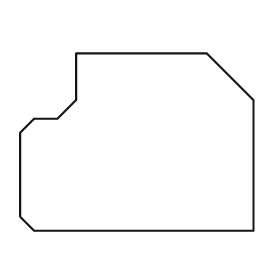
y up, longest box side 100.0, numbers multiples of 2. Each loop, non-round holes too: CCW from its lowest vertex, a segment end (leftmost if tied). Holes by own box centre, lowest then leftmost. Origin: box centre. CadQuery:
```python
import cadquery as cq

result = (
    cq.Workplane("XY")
    .moveTo(-44.0, -38.0)
    .lineTo(50.0, -38.0)
    .lineTo(50.0, 18.0)
    .lineTo(30.0, 38.0)
    .lineTo(-26.0, 38.0)
    .lineTo(-26.0, 18.0)
    .lineTo(-34.0, 10.0)
    .lineTo(-44.0, 10.0)
    .lineTo(-50.0, 4.0)
    .lineTo(-50.0, -32.0)
    .close()
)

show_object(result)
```